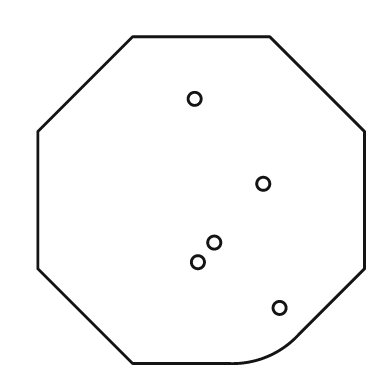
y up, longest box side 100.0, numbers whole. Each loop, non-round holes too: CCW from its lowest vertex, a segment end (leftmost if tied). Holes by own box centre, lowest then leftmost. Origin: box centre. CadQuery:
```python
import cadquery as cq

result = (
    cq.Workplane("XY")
    .moveTo(-21.0, -50.0)
    .lineTo(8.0, -50.0)
    .threePointArc((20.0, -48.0), (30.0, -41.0))
    .lineTo(50.0, -21.0)
    .lineTo(50.0, 21.0)
    .lineTo(21.0, 50.0)
    .lineTo(-21.0, 50.0)
    .lineTo(-50.0, 21.0)
    .lineTo(-50.0, -21.0)
    .close()
    .moveTo(24.0, -33.0)
    .circle(2.0)
    .moveTo(-1.0, -19.0)
    .circle(2.0)
    .moveTo(4.0, -13.0)
    .circle(2.0)
    .moveTo(19.0, 5.0)
    .circle(2.0)
    .moveTo(-2.0, 31.0)
    .circle(2.0)
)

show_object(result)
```